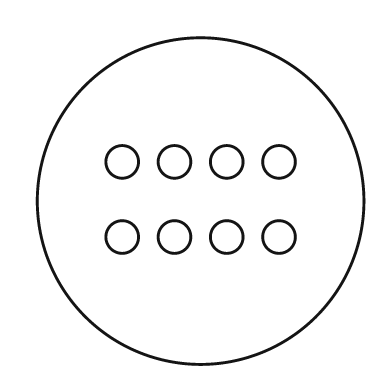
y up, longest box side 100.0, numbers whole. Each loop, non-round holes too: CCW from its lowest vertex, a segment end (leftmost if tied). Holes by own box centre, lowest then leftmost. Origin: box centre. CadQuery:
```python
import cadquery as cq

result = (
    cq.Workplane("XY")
    .moveTo(0.0, 0.0)
    .circle(50.0)
    .moveTo(-24.0, -11.0)
    .circle(5.0)
    .moveTo(-8.0, -11.0)
    .circle(5.0)
    .moveTo(8.0, -11.0)
    .circle(5.0)
    .moveTo(24.0, -11.0)
    .circle(5.0)
    .moveTo(-24.0, 12.0)
    .circle(5.0)
    .moveTo(-8.0, 12.0)
    .circle(5.0)
    .moveTo(8.0, 12.0)
    .circle(5.0)
    .moveTo(24.0, 12.0)
    .circle(5.0)
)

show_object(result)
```